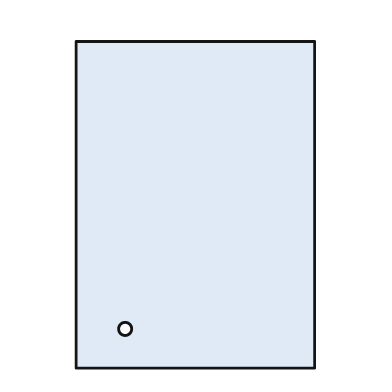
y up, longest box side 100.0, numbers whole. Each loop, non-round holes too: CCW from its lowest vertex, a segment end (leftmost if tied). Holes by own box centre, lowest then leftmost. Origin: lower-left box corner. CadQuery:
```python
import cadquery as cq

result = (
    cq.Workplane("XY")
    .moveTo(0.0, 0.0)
    .lineTo(73.0, 0.0)
    .lineTo(73.0, 100.0)
    .lineTo(0.0, 100.0)
    .close()
    .moveTo(15.0, 12.0)
    .circle(2.0)
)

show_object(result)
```